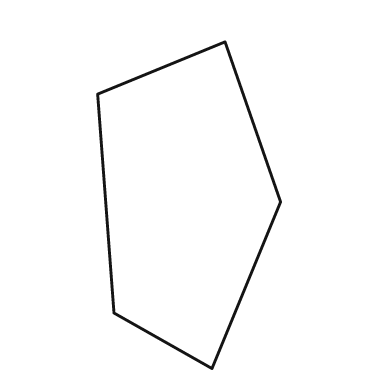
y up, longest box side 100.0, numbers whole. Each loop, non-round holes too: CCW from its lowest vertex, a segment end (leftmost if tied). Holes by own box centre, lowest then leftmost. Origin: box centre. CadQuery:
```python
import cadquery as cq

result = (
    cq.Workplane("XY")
    .moveTo(7.0, -50.0)
    .lineTo(28.0, 1.0)
    .lineTo(11.0, 50.0)
    .lineTo(-28.0, 34.0)
    .lineTo(-23.0, -33.0)
    .close()
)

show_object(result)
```